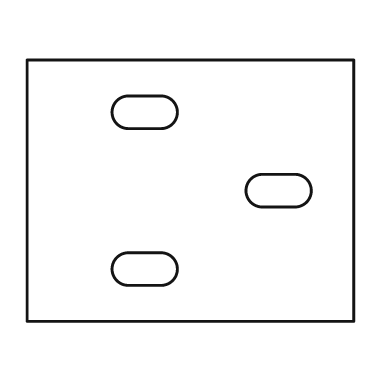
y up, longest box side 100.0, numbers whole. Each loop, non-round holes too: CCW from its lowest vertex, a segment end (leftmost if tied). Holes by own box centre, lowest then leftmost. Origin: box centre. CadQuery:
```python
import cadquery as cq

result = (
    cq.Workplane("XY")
    .moveTo(-50.0, -40.0)
    .lineTo(50.0, -40.0)
    .lineTo(50.0, 40.0)
    .lineTo(-50.0, 40.0)
    .close()
    .moveTo(-19.0, -29.0)
    .lineTo(-9.0, -29.0)
    .threePointArc((-4.0, -24.0), (-9.0, -19.0))
    .lineTo(-19.0, -19.0)
    .threePointArc((-24.0, -24.0), (-19.0, -29.0))
    .close()
    .moveTo(22.0, -5.0)
    .lineTo(32.0, -5.0)
    .threePointArc((37.0, 0.0), (32.0, 5.0))
    .lineTo(22.0, 5.0)
    .threePointArc((17.0, 0.0), (22.0, -5.0))
    .close()
    .moveTo(-19.0, 19.0)
    .lineTo(-9.0, 19.0)
    .threePointArc((-4.0, 24.0), (-9.0, 29.0))
    .lineTo(-19.0, 29.0)
    .threePointArc((-24.0, 24.0), (-19.0, 19.0))
    .close()
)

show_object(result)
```